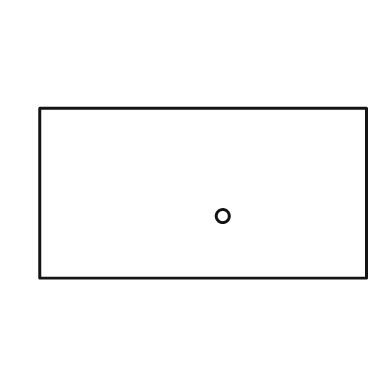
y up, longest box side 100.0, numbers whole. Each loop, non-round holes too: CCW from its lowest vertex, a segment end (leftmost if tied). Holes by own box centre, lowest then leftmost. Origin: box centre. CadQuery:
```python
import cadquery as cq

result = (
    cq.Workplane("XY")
    .moveTo(-50.0, -26.0)
    .lineTo(50.0, -26.0)
    .lineTo(50.0, 26.0)
    .lineTo(-50.0, 26.0)
    .close()
    .moveTo(6.0, -7.0)
    .circle(2.0)
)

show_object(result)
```